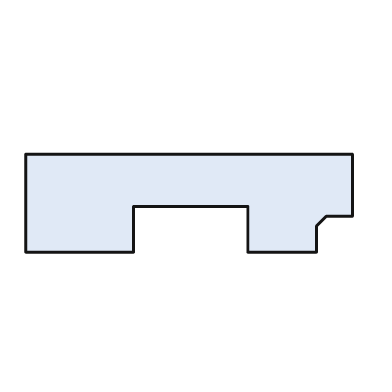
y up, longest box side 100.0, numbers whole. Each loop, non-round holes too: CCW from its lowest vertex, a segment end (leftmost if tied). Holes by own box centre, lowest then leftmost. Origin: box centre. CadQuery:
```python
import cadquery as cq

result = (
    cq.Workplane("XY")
    .moveTo(-50.0, -15.0)
    .lineTo(-17.0, -15.0)
    .lineTo(-17.0, -1.0)
    .lineTo(18.0, -1.0)
    .lineTo(18.0, -15.0)
    .lineTo(39.0, -15.0)
    .lineTo(39.0, -7.0)
    .lineTo(42.0, -4.0)
    .lineTo(50.0, -4.0)
    .lineTo(50.0, 15.0)
    .lineTo(-50.0, 15.0)
    .close()
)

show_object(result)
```